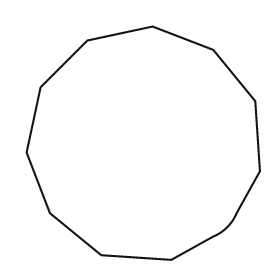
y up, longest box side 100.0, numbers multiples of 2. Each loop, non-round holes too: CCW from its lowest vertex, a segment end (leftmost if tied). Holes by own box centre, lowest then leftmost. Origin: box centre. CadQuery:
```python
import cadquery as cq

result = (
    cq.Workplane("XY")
    .moveTo(12.0, -50.0)
    .lineTo(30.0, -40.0)
    .threePointArc((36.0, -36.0), (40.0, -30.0))
    .lineTo(50.0, -12.0)
    .lineTo(48.0, 18.0)
    .lineTo(30.0, 40.0)
    .lineTo(4.0, 50.0)
    .lineTo(-24.0, 44.0)
    .lineTo(-44.0, 24.0)
    .lineTo(-50.0, -4.0)
    .lineTo(-40.0, -30.0)
    .lineTo(-18.0, -48.0)
    .close()
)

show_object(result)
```